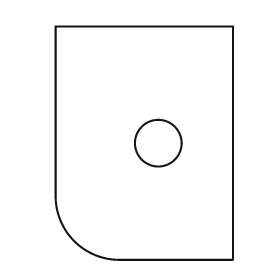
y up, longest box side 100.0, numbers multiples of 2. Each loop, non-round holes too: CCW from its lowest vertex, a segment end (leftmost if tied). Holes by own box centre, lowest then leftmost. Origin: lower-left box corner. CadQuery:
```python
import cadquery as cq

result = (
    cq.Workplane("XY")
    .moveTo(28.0, 0.0)
    .lineTo(76.0, 0.0)
    .lineTo(76.0, 100.0)
    .lineTo(0.0, 100.0)
    .lineTo(0.0, 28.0)
    .threePointArc((8.0, 8.0), (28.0, 0.0))
    .close()
    .moveTo(44.0, 50.0)
    .circle(10.0)
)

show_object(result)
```